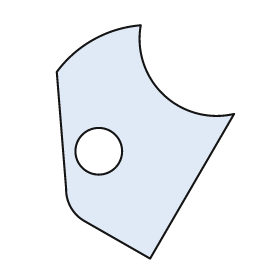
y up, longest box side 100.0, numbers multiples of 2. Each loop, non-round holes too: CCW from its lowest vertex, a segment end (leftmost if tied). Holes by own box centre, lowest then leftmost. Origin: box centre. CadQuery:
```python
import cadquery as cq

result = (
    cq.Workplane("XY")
    .moveTo(2.0, -50.0)
    .lineTo(38.0, 12.0)
    .threePointArc((8.0, 20.0), (-2.0, 50.0))
    .threePointArc((-22.0, 44.0), (-38.0, 30.0))
    .lineTo(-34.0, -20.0)
    .threePointArc((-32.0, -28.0), (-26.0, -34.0))
    .close()
    .moveTo(-20.0, -4.0)
    .circle(10.0)
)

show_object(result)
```